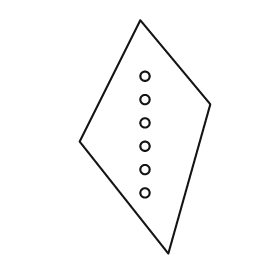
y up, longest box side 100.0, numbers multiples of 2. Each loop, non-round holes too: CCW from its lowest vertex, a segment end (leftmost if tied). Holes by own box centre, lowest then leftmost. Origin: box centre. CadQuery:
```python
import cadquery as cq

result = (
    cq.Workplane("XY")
    .moveTo(10.0, -50.0)
    .lineTo(28.0, 14.0)
    .lineTo(-2.0, 50.0)
    .lineTo(-28.0, -2.0)
    .close()
    .moveTo(0.0, -24.0)
    .circle(2.0)
    .moveTo(0.0, -14.0)
    .circle(2.0)
    .moveTo(0.0, -4.0)
    .circle(2.0)
    .moveTo(0.0, 6.0)
    .circle(2.0)
    .moveTo(0.0, 16.0)
    .circle(2.0)
    .moveTo(0.0, 26.0)
    .circle(2.0)
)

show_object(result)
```